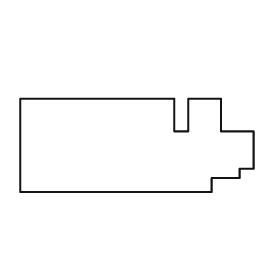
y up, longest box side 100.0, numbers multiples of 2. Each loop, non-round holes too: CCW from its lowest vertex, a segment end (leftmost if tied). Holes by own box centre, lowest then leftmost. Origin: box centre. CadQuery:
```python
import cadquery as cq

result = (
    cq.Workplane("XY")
    .moveTo(-50.0, -20.0)
    .lineTo(32.0, -20.0)
    .lineTo(32.0, -14.0)
    .lineTo(44.0, -14.0)
    .lineTo(44.0, -10.0)
    .lineTo(50.0, -10.0)
    .lineTo(50.0, 6.0)
    .lineTo(36.0, 6.0)
    .lineTo(36.0, 20.0)
    .lineTo(22.0, 20.0)
    .lineTo(22.0, 6.0)
    .lineTo(16.0, 6.0)
    .lineTo(16.0, 20.0)
    .lineTo(-50.0, 20.0)
    .close()
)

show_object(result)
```